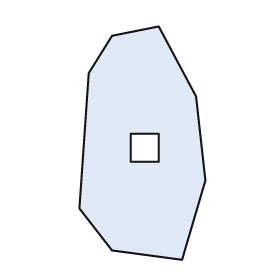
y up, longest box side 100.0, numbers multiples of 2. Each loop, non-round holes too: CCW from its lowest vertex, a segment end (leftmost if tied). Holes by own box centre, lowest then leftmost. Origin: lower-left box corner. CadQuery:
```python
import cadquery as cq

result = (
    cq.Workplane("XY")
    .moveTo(44.0, 0.0)
    .lineTo(54.0, 34.0)
    .lineTo(50.0, 70.0)
    .lineTo(34.0, 100.0)
    .lineTo(14.0, 96.0)
    .lineTo(4.0, 80.0)
    .lineTo(0.0, 22.0)
    .lineTo(14.0, 4.0)
    .close()
    .moveTo(22.0, 42.0)
    .lineTo(34.0, 42.0)
    .lineTo(34.0, 54.0)
    .lineTo(22.0, 54.0)
    .close()
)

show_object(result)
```